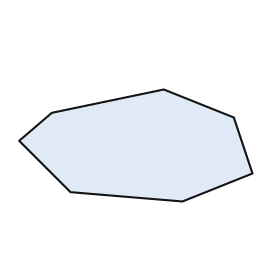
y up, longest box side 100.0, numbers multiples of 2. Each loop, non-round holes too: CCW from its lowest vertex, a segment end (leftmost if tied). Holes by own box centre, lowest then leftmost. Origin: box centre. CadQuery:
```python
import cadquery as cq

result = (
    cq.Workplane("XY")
    .moveTo(20.0, -24.0)
    .lineTo(50.0, -12.0)
    .lineTo(42.0, 12.0)
    .lineTo(12.0, 24.0)
    .lineTo(-36.0, 14.0)
    .lineTo(-50.0, 2.0)
    .lineTo(-28.0, -20.0)
    .close()
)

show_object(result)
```